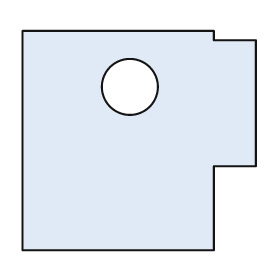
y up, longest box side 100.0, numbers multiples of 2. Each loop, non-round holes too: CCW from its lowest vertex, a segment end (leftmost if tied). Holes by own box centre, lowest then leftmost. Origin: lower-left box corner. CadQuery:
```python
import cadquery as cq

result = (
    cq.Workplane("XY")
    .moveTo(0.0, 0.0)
    .lineTo(82.0, 0.0)
    .lineTo(82.0, 36.0)
    .lineTo(100.0, 36.0)
    .lineTo(100.0, 90.0)
    .lineTo(82.0, 90.0)
    .lineTo(82.0, 94.0)
    .lineTo(0.0, 94.0)
    .close()
    .moveTo(46.0, 70.0)
    .circle(12.0)
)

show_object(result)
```